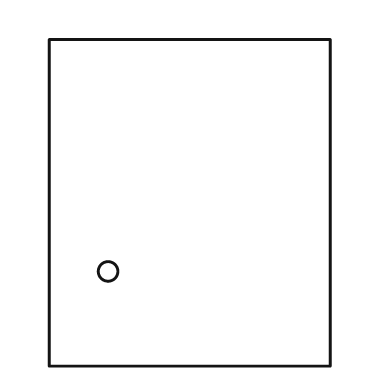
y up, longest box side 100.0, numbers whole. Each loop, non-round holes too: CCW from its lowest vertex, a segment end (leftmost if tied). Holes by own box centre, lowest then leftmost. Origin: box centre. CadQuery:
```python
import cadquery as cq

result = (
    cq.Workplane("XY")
    .moveTo(-43.0, -50.0)
    .lineTo(43.0, -50.0)
    .lineTo(43.0, 50.0)
    .lineTo(-43.0, 50.0)
    .close()
    .moveTo(-25.0, -21.0)
    .circle(3.0)
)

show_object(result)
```